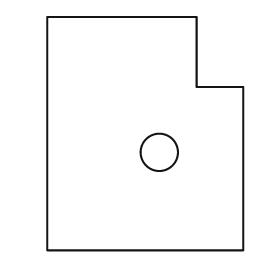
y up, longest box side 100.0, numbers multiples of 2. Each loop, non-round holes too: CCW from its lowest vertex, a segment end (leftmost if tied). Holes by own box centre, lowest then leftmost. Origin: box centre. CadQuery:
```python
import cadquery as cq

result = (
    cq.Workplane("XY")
    .moveTo(-42.0, -50.0)
    .lineTo(42.0, -50.0)
    .lineTo(42.0, 20.0)
    .lineTo(22.0, 20.0)
    .lineTo(22.0, 50.0)
    .lineTo(-42.0, 50.0)
    .close()
    .moveTo(6.0, -8.0)
    .circle(8.0)
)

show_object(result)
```